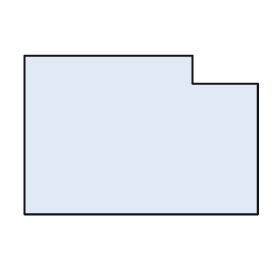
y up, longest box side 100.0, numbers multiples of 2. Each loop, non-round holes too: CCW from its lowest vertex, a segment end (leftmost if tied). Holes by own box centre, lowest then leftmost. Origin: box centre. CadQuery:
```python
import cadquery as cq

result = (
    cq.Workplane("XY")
    .moveTo(-50.0, -34.0)
    .lineTo(50.0, -34.0)
    .lineTo(50.0, 22.0)
    .lineTo(22.0, 22.0)
    .lineTo(22.0, 34.0)
    .lineTo(-50.0, 34.0)
    .close()
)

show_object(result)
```